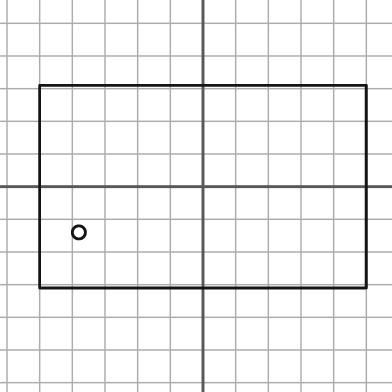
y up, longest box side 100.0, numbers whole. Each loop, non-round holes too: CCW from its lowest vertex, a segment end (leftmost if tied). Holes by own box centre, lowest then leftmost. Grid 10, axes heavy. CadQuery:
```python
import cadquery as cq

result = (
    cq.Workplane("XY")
    .moveTo(-50.0, -31.0)
    .lineTo(50.0, -31.0)
    .lineTo(50.0, 31.0)
    .lineTo(-50.0, 31.0)
    .close()
    .moveTo(-38.0, -14.0)
    .circle(2.0)
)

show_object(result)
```